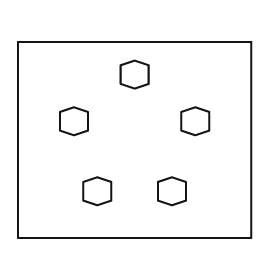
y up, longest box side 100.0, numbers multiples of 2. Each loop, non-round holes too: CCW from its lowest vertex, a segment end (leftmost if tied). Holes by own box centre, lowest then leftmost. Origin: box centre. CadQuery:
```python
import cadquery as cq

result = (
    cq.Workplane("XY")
    .moveTo(-50.0, -42.0)
    .lineTo(50.0, -42.0)
    .lineTo(50.0, 42.0)
    .lineTo(-50.0, 42.0)
    .close()
    .moveTo(-16.0, -28.0)
    .lineTo(-10.0, -26.0)
    .lineTo(-10.0, -18.0)
    .lineTo(-16.0, -16.0)
    .lineTo(-22.0, -18.0)
    .lineTo(-22.0, -26.0)
    .close()
    .moveTo(16.0, -28.0)
    .lineTo(22.0, -26.0)
    .lineTo(22.0, -18.0)
    .lineTo(16.0, -16.0)
    .lineTo(10.0, -18.0)
    .lineTo(10.0, -26.0)
    .close()
    .moveTo(-26.0, 2.0)
    .lineTo(-20.0, 4.0)
    .lineTo(-20.0, 12.0)
    .lineTo(-26.0, 14.0)
    .lineTo(-32.0, 12.0)
    .lineTo(-32.0, 4.0)
    .close()
    .moveTo(26.0, 2.0)
    .lineTo(32.0, 4.0)
    .lineTo(32.0, 12.0)
    .lineTo(26.0, 14.0)
    .lineTo(20.0, 12.0)
    .lineTo(20.0, 4.0)
    .close()
    .moveTo(0.0, 22.0)
    .lineTo(6.0, 24.0)
    .lineTo(6.0, 32.0)
    .lineTo(0.0, 34.0)
    .lineTo(-6.0, 32.0)
    .lineTo(-6.0, 24.0)
    .close()
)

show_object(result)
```